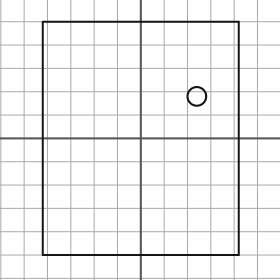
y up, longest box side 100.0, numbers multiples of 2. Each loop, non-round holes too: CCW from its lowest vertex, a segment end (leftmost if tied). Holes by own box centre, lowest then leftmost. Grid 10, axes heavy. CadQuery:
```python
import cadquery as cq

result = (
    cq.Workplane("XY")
    .moveTo(-42.0, -50.0)
    .lineTo(42.0, -50.0)
    .lineTo(42.0, 50.0)
    .lineTo(-42.0, 50.0)
    .close()
    .moveTo(24.0, 18.0)
    .circle(4.0)
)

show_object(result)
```